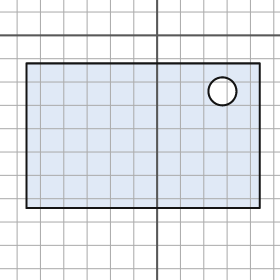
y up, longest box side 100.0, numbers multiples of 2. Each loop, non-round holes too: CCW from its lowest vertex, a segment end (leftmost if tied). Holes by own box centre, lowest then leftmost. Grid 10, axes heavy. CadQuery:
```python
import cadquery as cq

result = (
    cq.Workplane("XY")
    .moveTo(-56.0, -74.0)
    .lineTo(44.0, -74.0)
    .lineTo(44.0, -12.0)
    .lineTo(-56.0, -12.0)
    .close()
    .moveTo(28.0, -24.0)
    .circle(6.0)
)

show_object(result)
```